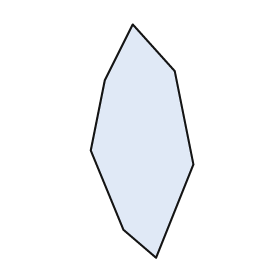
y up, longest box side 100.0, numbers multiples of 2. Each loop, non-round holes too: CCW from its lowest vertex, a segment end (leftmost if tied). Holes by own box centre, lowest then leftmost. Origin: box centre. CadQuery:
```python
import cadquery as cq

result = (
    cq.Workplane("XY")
    .moveTo(6.0, -50.0)
    .lineTo(22.0, -10.0)
    .lineTo(14.0, 30.0)
    .lineTo(-4.0, 50.0)
    .lineTo(-16.0, 26.0)
    .lineTo(-22.0, -4.0)
    .lineTo(-8.0, -38.0)
    .close()
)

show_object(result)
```